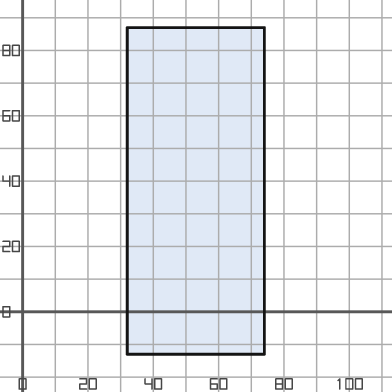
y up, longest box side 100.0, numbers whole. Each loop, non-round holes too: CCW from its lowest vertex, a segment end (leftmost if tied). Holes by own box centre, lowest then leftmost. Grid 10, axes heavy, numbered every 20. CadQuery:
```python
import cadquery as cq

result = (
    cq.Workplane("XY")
    .moveTo(32.0, -13.0)
    .lineTo(74.0, -13.0)
    .lineTo(74.0, 87.0)
    .lineTo(32.0, 87.0)
    .close()
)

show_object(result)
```